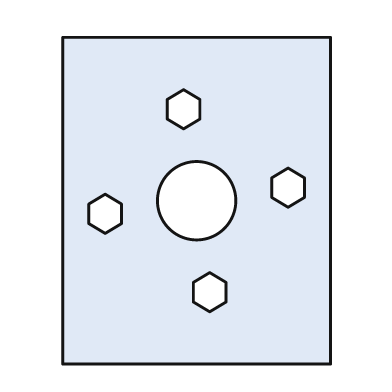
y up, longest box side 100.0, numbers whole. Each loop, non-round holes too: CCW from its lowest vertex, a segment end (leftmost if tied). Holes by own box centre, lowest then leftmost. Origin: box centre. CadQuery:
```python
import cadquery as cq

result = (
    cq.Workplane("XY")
    .moveTo(-41.0, -50.0)
    .lineTo(41.0, -50.0)
    .lineTo(41.0, 50.0)
    .lineTo(-41.0, 50.0)
    .close()
    .moveTo(4.0, -34.0)
    .lineTo(9.0, -31.0)
    .lineTo(9.0, -25.0)
    .lineTo(4.0, -22.0)
    .lineTo(-1.0, -25.0)
    .lineTo(-1.0, -31.0)
    .close()
    .moveTo(-28.0, -10.0)
    .lineTo(-23.0, -7.0)
    .lineTo(-23.0, -1.0)
    .lineTo(-28.0, 2.0)
    .lineTo(-33.0, -1.0)
    .lineTo(-33.0, -7.0)
    .close()
    .moveTo(0.0, 0.0)
    .circle(12.0)
    .moveTo(28.0, -2.0)
    .lineTo(33.0, 1.0)
    .lineTo(33.0, 7.0)
    .lineTo(28.0, 10.0)
    .lineTo(23.0, 7.0)
    .lineTo(23.0, 1.0)
    .close()
    .moveTo(-4.0, 22.0)
    .lineTo(1.0, 25.0)
    .lineTo(1.0, 31.0)
    .lineTo(-4.0, 34.0)
    .lineTo(-9.0, 31.0)
    .lineTo(-9.0, 25.0)
    .close()
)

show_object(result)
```